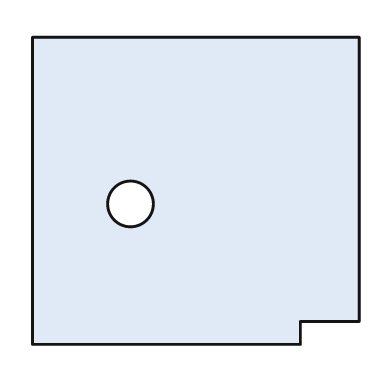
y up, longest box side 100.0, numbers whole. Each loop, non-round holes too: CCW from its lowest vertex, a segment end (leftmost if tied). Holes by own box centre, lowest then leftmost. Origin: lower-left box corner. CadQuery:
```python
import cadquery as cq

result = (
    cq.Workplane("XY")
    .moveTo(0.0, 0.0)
    .lineTo(82.0, 0.0)
    .lineTo(82.0, 7.0)
    .lineTo(100.0, 7.0)
    .lineTo(100.0, 94.0)
    .lineTo(0.0, 94.0)
    .close()
    .moveTo(30.0, 43.0)
    .circle(7.0)
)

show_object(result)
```